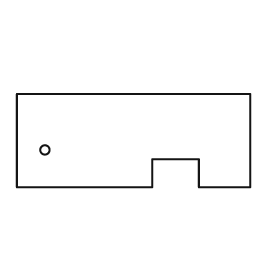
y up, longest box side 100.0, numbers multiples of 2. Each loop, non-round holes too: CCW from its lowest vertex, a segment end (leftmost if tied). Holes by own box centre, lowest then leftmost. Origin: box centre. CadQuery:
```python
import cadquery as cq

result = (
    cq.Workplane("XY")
    .moveTo(-50.0, -20.0)
    .lineTo(8.0, -20.0)
    .lineTo(8.0, -8.0)
    .lineTo(28.0, -8.0)
    .lineTo(28.0, -20.0)
    .lineTo(50.0, -20.0)
    .lineTo(50.0, 20.0)
    .lineTo(-50.0, 20.0)
    .close()
    .moveTo(-38.0, -4.0)
    .circle(2.0)
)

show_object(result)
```